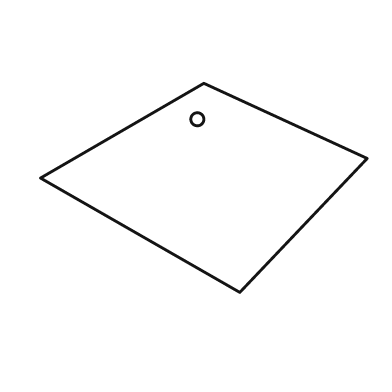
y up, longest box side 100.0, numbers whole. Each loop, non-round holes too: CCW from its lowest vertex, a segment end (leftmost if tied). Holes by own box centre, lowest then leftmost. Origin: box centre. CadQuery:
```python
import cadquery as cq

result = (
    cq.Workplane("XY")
    .moveTo(11.0, -32.0)
    .lineTo(50.0, 9.0)
    .lineTo(0.0, 32.0)
    .lineTo(-50.0, 3.0)
    .close()
    .moveTo(-2.0, 21.0)
    .circle(2.0)
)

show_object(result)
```